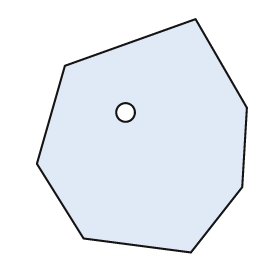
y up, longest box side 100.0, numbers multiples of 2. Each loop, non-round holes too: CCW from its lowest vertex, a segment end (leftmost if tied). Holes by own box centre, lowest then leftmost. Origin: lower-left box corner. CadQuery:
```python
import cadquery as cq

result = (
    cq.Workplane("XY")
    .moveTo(66.0, 0.0)
    .lineTo(88.0, 28.0)
    .lineTo(90.0, 62.0)
    .lineTo(68.0, 100.0)
    .lineTo(12.0, 80.0)
    .lineTo(0.0, 38.0)
    .lineTo(20.0, 6.0)
    .close()
    .moveTo(38.0, 60.0)
    .circle(4.0)
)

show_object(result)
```